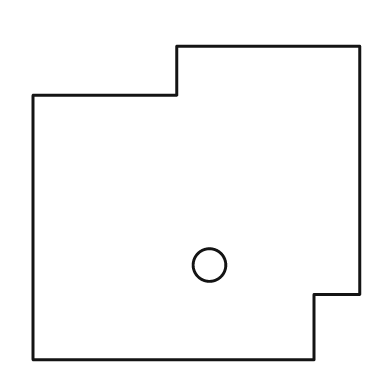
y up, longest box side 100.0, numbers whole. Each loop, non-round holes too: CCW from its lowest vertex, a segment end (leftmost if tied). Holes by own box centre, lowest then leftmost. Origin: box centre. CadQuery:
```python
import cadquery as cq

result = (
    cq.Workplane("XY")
    .moveTo(-50.0, -48.0)
    .lineTo(36.0, -48.0)
    .lineTo(36.0, -28.0)
    .lineTo(50.0, -28.0)
    .lineTo(50.0, 48.0)
    .lineTo(-6.0, 48.0)
    .lineTo(-6.0, 33.0)
    .lineTo(-50.0, 33.0)
    .close()
    .moveTo(4.0, -19.0)
    .circle(5.0)
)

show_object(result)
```